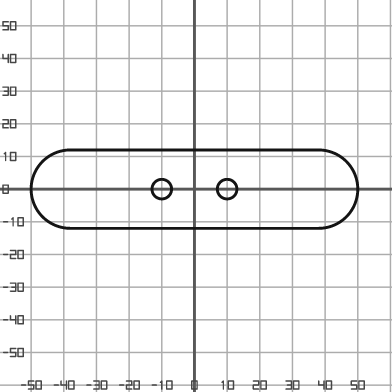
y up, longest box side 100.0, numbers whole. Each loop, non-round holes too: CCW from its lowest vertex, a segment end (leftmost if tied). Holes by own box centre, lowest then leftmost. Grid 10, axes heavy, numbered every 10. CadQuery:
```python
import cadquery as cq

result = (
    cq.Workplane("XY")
    .moveTo(-38.0, -12.0)
    .lineTo(38.0, -12.0)
    .threePointArc((50.0, 0.0), (38.0, 12.0))
    .lineTo(-38.0, 12.0)
    .threePointArc((-50.0, 0.0), (-38.0, -12.0))
    .close()
    .moveTo(-10.0, 0.0)
    .circle(3.0)
    .moveTo(10.0, 0.0)
    .circle(3.0)
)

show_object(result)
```